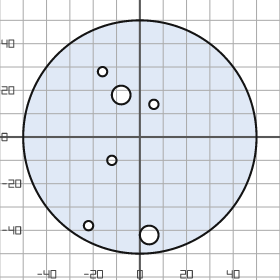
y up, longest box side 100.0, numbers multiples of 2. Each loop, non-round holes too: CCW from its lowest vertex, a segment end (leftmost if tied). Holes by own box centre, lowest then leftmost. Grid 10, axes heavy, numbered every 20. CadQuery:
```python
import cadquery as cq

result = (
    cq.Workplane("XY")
    .moveTo(0.0, 0.0)
    .circle(50.0)
    .moveTo(4.0, -42.0)
    .circle(4.0)
    .moveTo(-22.0, -38.0)
    .circle(2.0)
    .moveTo(-12.0, -10.0)
    .circle(2.0)
    .moveTo(6.0, 14.0)
    .circle(2.0)
    .moveTo(-8.0, 18.0)
    .circle(4.0)
    .moveTo(-16.0, 28.0)
    .circle(2.0)
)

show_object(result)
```